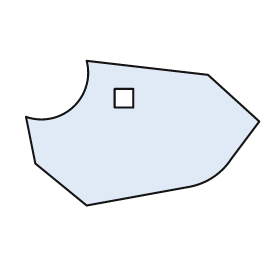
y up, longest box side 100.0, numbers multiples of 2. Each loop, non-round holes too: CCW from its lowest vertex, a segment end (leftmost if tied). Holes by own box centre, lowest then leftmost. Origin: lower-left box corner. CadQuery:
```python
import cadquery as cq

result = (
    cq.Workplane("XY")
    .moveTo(26.0, 0.0)
    .lineTo(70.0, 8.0)
    .threePointArc((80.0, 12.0), (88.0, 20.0))
    .lineTo(100.0, 36.0)
    .lineTo(78.0, 56.0)
    .lineTo(26.0, 62.0)
    .threePointArc((20.0, 42.0), (0.0, 38.0))
    .lineTo(4.0, 18.0)
    .close()
    .moveTo(38.0, 42.0)
    .lineTo(46.0, 42.0)
    .lineTo(46.0, 50.0)
    .lineTo(38.0, 50.0)
    .close()
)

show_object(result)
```